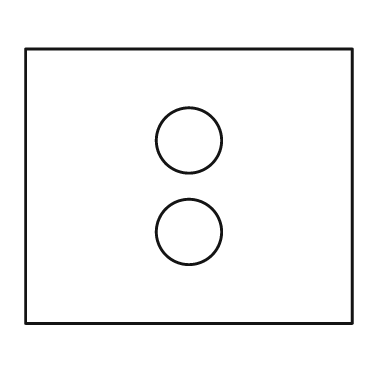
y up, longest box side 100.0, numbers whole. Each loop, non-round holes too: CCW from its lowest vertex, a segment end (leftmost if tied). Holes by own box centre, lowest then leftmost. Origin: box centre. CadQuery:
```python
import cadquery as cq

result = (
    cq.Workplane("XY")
    .moveTo(-50.0, -42.0)
    .lineTo(50.0, -42.0)
    .lineTo(50.0, 42.0)
    .lineTo(-50.0, 42.0)
    .close()
    .moveTo(0.0, -14.0)
    .circle(10.0)
    .moveTo(0.0, 14.0)
    .circle(10.0)
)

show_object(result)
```